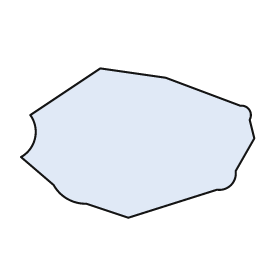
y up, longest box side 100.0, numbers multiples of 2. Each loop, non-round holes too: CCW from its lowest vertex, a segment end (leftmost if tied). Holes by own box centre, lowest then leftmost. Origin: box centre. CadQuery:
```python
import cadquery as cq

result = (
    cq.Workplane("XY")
    .moveTo(-4.0, -32.0)
    .lineTo(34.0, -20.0)
    .threePointArc((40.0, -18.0), (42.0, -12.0))
    .lineTo(50.0, 2.0)
    .lineTo(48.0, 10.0)
    .threePointArc((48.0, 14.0), (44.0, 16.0))
    .lineTo(12.0, 28.0)
    .lineTo(-16.0, 32.0)
    .lineTo(-46.0, 12.0)
    .threePointArc((-44.0, 2.0), (-50.0, -6.0))
    .lineTo(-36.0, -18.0)
    .threePointArc((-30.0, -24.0), (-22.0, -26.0))
    .close()
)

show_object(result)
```